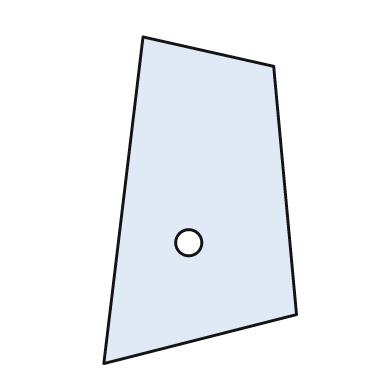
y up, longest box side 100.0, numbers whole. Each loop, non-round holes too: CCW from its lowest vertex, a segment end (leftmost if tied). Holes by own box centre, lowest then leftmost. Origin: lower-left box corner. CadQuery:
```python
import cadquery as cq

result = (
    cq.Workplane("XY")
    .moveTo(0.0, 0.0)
    .lineTo(59.0, 15.0)
    .lineTo(52.0, 91.0)
    .lineTo(12.0, 100.0)
    .close()
    .moveTo(26.0, 37.0)
    .circle(4.0)
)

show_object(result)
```